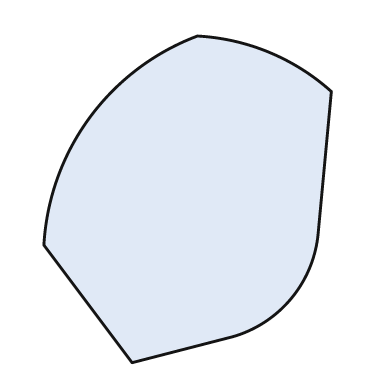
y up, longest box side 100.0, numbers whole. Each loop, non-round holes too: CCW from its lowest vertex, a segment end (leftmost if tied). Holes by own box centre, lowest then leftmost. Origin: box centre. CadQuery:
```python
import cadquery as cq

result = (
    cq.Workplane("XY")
    .moveTo(-17.0, -50.0)
    .lineTo(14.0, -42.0)
    .threePointArc((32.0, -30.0), (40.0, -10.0))
    .lineTo(44.0, 33.0)
    .threePointArc((25.0, 45.0), (3.0, 50.0))
    .threePointArc((-30.0, 25.0), (-44.0, -14.0))
    .close()
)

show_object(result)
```